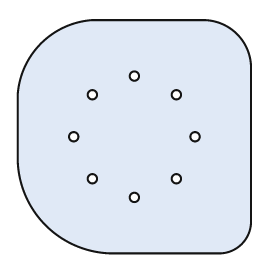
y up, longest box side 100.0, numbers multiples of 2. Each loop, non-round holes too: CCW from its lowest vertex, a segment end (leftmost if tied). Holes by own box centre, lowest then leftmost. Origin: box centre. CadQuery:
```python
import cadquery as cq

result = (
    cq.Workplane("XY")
    .moveTo(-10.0, -50.0)
    .lineTo(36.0, -50.0)
    .threePointArc((46.0, -46.0), (50.0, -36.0))
    .lineTo(50.0, 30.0)
    .threePointArc((44.0, 44.0), (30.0, 50.0))
    .lineTo(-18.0, 50.0)
    .threePointArc((-40.0, 40.0), (-50.0, 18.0))
    .lineTo(-50.0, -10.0)
    .threePointArc((-38.0, -38.0), (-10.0, -50.0))
    .close()
    .moveTo(0.0, -26.0)
    .circle(2.0)
    .moveTo(-18.0, -18.0)
    .circle(2.0)
    .moveTo(18.0, -18.0)
    .circle(2.0)
    .moveTo(-26.0, 0.0)
    .circle(2.0)
    .moveTo(26.0, 0.0)
    .circle(2.0)
    .moveTo(-18.0, 18.0)
    .circle(2.0)
    .moveTo(18.0, 18.0)
    .circle(2.0)
    .moveTo(0.0, 26.0)
    .circle(2.0)
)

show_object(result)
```